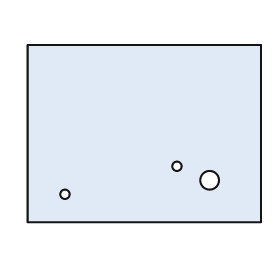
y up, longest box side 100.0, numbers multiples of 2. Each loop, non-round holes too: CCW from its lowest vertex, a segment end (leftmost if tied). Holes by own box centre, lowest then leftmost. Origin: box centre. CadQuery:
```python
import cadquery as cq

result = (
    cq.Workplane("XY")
    .moveTo(-50.0, -38.0)
    .lineTo(50.0, -38.0)
    .lineTo(50.0, 38.0)
    .lineTo(-50.0, 38.0)
    .close()
    .moveTo(-34.0, -26.0)
    .circle(2.0)
    .moveTo(28.0, -20.0)
    .circle(4.0)
    .moveTo(14.0, -14.0)
    .circle(2.0)
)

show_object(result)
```